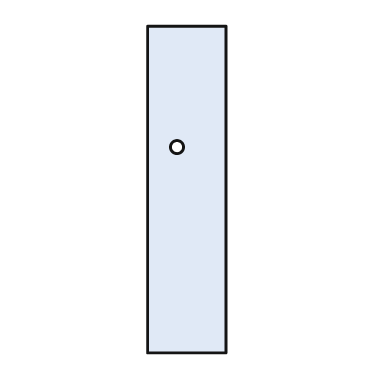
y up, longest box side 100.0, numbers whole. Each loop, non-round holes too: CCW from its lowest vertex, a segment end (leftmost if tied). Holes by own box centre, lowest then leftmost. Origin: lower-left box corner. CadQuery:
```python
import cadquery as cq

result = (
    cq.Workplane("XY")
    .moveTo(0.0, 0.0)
    .lineTo(24.0, 0.0)
    .lineTo(24.0, 100.0)
    .lineTo(0.0, 100.0)
    .close()
    .moveTo(9.0, 63.0)
    .circle(2.0)
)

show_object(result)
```